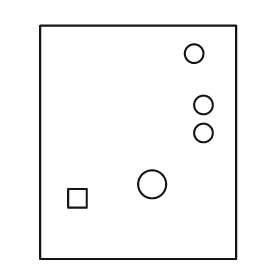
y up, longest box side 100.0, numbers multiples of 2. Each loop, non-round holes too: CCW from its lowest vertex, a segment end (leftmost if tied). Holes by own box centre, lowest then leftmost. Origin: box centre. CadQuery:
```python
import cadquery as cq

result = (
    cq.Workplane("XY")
    .moveTo(-42.0, -50.0)
    .lineTo(42.0, -50.0)
    .lineTo(42.0, 50.0)
    .lineTo(-42.0, 50.0)
    .close()
    .moveTo(-30.0, -28.0)
    .lineTo(-22.0, -28.0)
    .lineTo(-22.0, -20.0)
    .lineTo(-30.0, -20.0)
    .close()
    .moveTo(6.0, -18.0)
    .circle(6.0)
    .moveTo(28.0, 4.0)
    .circle(4.0)
    .moveTo(28.0, 16.0)
    .circle(4.0)
    .moveTo(24.0, 38.0)
    .circle(4.0)
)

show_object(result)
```